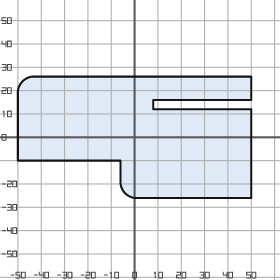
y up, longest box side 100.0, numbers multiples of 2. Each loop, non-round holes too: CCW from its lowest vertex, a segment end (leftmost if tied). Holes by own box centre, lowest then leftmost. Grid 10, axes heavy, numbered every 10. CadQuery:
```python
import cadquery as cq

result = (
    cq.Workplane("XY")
    .moveTo(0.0, -26.0)
    .lineTo(50.0, -26.0)
    .lineTo(50.0, 12.0)
    .lineTo(8.0, 12.0)
    .lineTo(8.0, 16.0)
    .lineTo(50.0, 16.0)
    .lineTo(50.0, 26.0)
    .lineTo(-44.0, 26.0)
    .threePointArc((-48.0, 24.0), (-50.0, 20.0))
    .lineTo(-50.0, -10.0)
    .lineTo(-6.0, -10.0)
    .lineTo(-6.0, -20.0)
    .threePointArc((-4.0, -24.0), (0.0, -26.0))
    .close()
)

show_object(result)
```